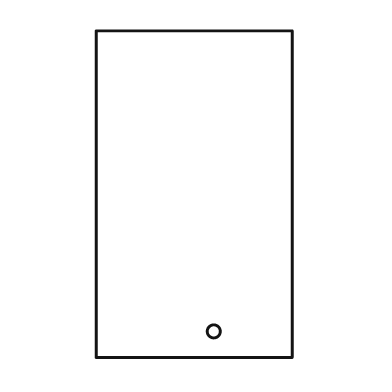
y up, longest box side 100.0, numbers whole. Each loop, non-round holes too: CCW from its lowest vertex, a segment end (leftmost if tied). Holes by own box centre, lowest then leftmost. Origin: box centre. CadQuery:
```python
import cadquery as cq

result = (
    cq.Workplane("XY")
    .moveTo(-30.0, -50.0)
    .lineTo(30.0, -50.0)
    .lineTo(30.0, 50.0)
    .lineTo(-30.0, 50.0)
    .close()
    .moveTo(6.0, -42.0)
    .circle(2.0)
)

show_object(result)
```